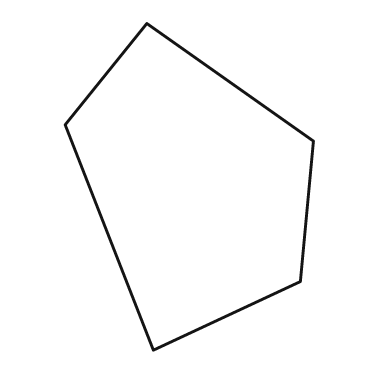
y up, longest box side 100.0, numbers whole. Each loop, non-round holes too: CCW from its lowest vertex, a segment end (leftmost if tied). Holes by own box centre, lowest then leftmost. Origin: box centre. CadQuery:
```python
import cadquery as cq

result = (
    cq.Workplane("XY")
    .moveTo(-11.0, -50.0)
    .lineTo(34.0, -29.0)
    .lineTo(38.0, 14.0)
    .lineTo(-13.0, 50.0)
    .lineTo(-38.0, 19.0)
    .close()
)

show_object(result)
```